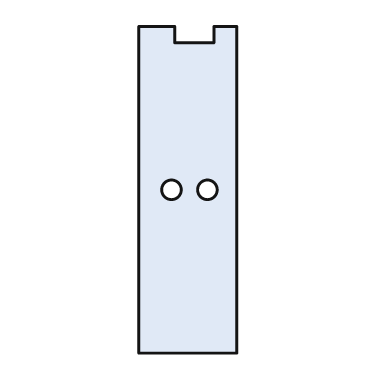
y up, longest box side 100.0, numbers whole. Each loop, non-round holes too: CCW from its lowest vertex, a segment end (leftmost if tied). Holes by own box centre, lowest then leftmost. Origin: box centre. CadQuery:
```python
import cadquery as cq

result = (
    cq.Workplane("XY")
    .moveTo(-15.0, -50.0)
    .lineTo(15.0, -50.0)
    .lineTo(15.0, 50.0)
    .lineTo(8.0, 50.0)
    .lineTo(8.0, 45.0)
    .lineTo(-4.0, 45.0)
    .lineTo(-4.0, 50.0)
    .lineTo(-15.0, 50.0)
    .close()
    .moveTo(-5.0, 0.0)
    .circle(3.0)
    .moveTo(6.0, 0.0)
    .circle(3.0)
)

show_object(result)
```